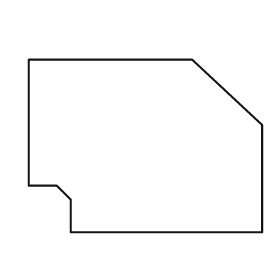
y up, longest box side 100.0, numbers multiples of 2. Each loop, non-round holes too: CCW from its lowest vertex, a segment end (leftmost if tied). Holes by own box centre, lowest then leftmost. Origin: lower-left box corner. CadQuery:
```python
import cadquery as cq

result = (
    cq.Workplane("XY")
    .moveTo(18.0, 0.0)
    .lineTo(100.0, 0.0)
    .lineTo(100.0, 46.0)
    .lineTo(70.0, 74.0)
    .lineTo(0.0, 74.0)
    .lineTo(0.0, 20.0)
    .lineTo(12.0, 20.0)
    .lineTo(18.0, 14.0)
    .close()
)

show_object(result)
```